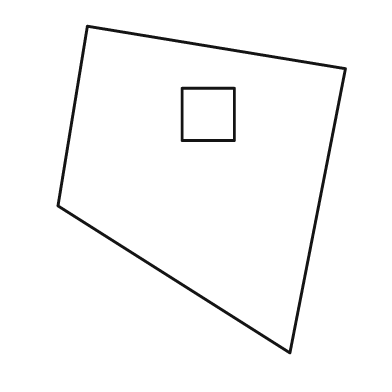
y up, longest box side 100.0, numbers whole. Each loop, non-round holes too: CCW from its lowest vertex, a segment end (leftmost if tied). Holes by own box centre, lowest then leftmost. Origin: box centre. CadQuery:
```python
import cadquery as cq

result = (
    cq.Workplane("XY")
    .moveTo(27.0, -50.0)
    .lineTo(44.0, 37.0)
    .lineTo(-35.0, 50.0)
    .lineTo(-44.0, -5.0)
    .close()
    .moveTo(-6.0, 15.0)
    .lineTo(10.0, 15.0)
    .lineTo(10.0, 31.0)
    .lineTo(-6.0, 31.0)
    .close()
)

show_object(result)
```